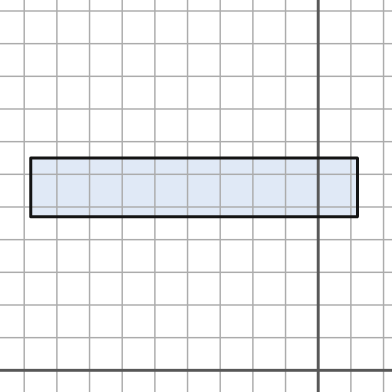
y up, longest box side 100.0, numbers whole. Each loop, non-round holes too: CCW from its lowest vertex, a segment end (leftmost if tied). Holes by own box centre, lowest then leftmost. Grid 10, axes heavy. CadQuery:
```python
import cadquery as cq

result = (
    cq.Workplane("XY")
    .moveTo(-88.0, 47.0)
    .lineTo(12.0, 47.0)
    .lineTo(12.0, 65.0)
    .lineTo(-88.0, 65.0)
    .close()
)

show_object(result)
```